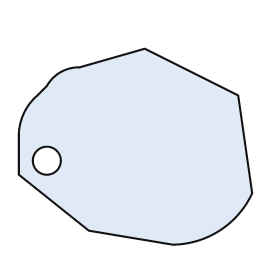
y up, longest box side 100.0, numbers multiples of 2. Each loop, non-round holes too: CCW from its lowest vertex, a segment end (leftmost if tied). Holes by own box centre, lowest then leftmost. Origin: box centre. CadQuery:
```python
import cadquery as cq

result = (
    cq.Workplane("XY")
    .moveTo(16.0, -42.0)
    .threePointArc((36.0, -36.0), (50.0, -20.0))
    .lineTo(44.0, 22.0)
    .lineTo(4.0, 42.0)
    .lineTo(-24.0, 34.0)
    .threePointArc((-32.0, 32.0), (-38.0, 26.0))
    .lineTo(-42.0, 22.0)
    .threePointArc((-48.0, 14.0), (-50.0, 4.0))
    .lineTo(-50.0, -12.0)
    .lineTo(-20.0, -36.0)
    .close()
    .moveTo(-38.0, -6.0)
    .circle(6.0)
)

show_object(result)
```